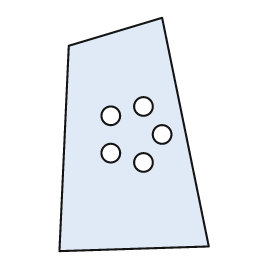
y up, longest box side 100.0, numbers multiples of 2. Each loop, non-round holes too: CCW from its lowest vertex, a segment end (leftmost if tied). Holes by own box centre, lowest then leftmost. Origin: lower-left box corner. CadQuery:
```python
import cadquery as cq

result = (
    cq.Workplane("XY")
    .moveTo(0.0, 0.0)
    .lineTo(64.0, 2.0)
    .lineTo(44.0, 100.0)
    .lineTo(4.0, 88.0)
    .close()
    .moveTo(36.0, 38.0)
    .circle(4.0)
    .moveTo(22.0, 42.0)
    .circle(4.0)
    .moveTo(44.0, 50.0)
    .circle(4.0)
    .moveTo(22.0, 58.0)
    .circle(4.0)
    .moveTo(36.0, 62.0)
    .circle(4.0)
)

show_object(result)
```